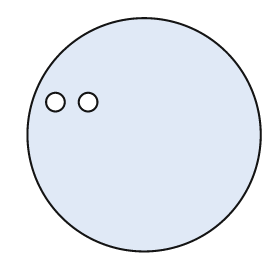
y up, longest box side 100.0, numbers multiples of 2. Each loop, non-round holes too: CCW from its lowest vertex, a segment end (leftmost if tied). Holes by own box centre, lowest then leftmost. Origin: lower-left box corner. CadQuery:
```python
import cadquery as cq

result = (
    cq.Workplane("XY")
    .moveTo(50.0, 50.0)
    .circle(50.0)
    .moveTo(12.0, 64.0)
    .circle(4.0)
    .moveTo(26.0, 64.0)
    .circle(4.0)
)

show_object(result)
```